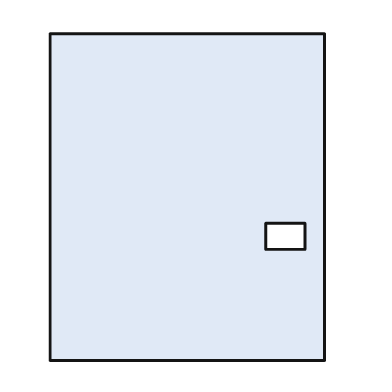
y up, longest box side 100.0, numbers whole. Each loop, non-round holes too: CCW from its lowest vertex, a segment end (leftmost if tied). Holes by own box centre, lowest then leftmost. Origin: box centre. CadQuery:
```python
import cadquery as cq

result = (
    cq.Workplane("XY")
    .moveTo(-42.0, -50.0)
    .lineTo(42.0, -50.0)
    .lineTo(42.0, 50.0)
    .lineTo(-42.0, 50.0)
    .close()
    .moveTo(24.0, -16.0)
    .lineTo(36.0, -16.0)
    .lineTo(36.0, -8.0)
    .lineTo(24.0, -8.0)
    .close()
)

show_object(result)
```